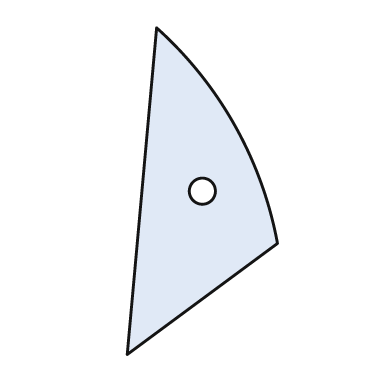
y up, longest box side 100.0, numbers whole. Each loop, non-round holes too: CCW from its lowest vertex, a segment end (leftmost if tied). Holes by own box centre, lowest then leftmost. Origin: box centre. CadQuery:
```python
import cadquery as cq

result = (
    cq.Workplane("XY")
    .moveTo(-23.0, -50.0)
    .lineTo(23.0, -16.0)
    .threePointArc((10.0, 20.0), (-14.0, 50.0))
    .close()
    .moveTo(0.0, 0.0)
    .circle(4.0)
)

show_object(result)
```